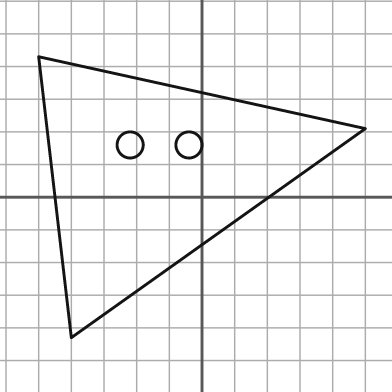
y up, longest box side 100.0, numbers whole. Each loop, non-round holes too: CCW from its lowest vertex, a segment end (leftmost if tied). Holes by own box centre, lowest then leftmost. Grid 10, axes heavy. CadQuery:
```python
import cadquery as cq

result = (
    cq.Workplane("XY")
    .moveTo(-40.0, -43.0)
    .lineTo(50.0, 21.0)
    .lineTo(-50.0, 43.0)
    .close()
    .moveTo(-22.0, 16.0)
    .circle(4.0)
    .moveTo(-4.0, 16.0)
    .circle(4.0)
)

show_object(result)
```